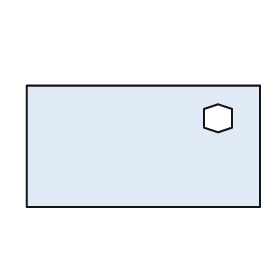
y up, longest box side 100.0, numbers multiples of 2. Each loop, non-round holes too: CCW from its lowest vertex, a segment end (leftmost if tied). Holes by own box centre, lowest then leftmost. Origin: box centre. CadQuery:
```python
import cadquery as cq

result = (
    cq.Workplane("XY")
    .moveTo(-50.0, -26.0)
    .lineTo(50.0, -26.0)
    .lineTo(50.0, 26.0)
    .lineTo(-50.0, 26.0)
    .close()
    .moveTo(32.0, 6.0)
    .lineTo(38.0, 8.0)
    .lineTo(38.0, 16.0)
    .lineTo(32.0, 18.0)
    .lineTo(26.0, 16.0)
    .lineTo(26.0, 8.0)
    .close()
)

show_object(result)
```